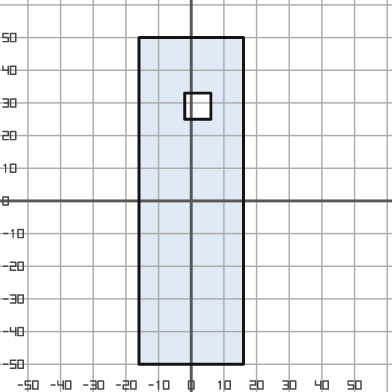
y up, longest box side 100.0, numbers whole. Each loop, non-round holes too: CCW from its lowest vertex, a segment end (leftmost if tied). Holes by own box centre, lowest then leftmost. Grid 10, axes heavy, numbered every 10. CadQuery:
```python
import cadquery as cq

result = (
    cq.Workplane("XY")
    .moveTo(-16.0, -50.0)
    .lineTo(16.0, -50.0)
    .lineTo(16.0, 50.0)
    .lineTo(-16.0, 50.0)
    .close()
    .moveTo(-2.0, 25.0)
    .lineTo(6.0, 25.0)
    .lineTo(6.0, 33.0)
    .lineTo(-2.0, 33.0)
    .close()
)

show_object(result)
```